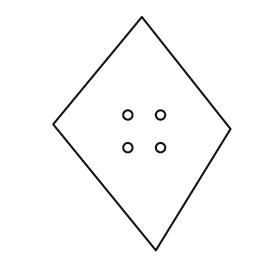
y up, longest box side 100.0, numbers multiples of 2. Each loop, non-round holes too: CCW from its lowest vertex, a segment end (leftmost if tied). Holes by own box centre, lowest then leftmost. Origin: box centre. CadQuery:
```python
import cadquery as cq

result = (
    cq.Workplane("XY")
    .moveTo(6.0, -50.0)
    .lineTo(38.0, 2.0)
    .lineTo(0.0, 50.0)
    .lineTo(-38.0, 4.0)
    .close()
    .moveTo(-6.0, -6.0)
    .circle(2.0)
    .moveTo(8.0, -6.0)
    .circle(2.0)
    .moveTo(-6.0, 8.0)
    .circle(2.0)
    .moveTo(8.0, 8.0)
    .circle(2.0)
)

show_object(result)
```